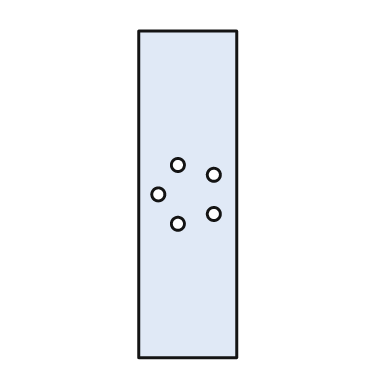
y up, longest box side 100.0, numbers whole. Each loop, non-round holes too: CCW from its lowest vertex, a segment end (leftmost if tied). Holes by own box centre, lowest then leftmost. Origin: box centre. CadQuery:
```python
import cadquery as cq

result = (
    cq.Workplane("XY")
    .moveTo(-15.0, -50.0)
    .lineTo(15.0, -50.0)
    .lineTo(15.0, 50.0)
    .lineTo(-15.0, 50.0)
    .close()
    .moveTo(-3.0, -9.0)
    .circle(2.0)
    .moveTo(8.0, -6.0)
    .circle(2.0)
    .moveTo(-9.0, 0.0)
    .circle(2.0)
    .moveTo(8.0, 6.0)
    .circle(2.0)
    .moveTo(-3.0, 9.0)
    .circle(2.0)
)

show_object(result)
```